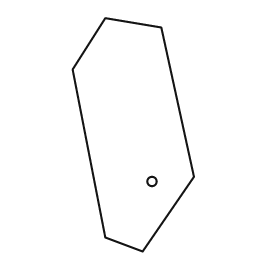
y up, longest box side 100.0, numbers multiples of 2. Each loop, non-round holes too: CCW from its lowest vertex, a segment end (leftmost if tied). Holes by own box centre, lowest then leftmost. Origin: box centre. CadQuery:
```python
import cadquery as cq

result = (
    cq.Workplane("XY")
    .moveTo(4.0, -50.0)
    .lineTo(26.0, -18.0)
    .lineTo(12.0, 46.0)
    .lineTo(-12.0, 50.0)
    .lineTo(-26.0, 28.0)
    .lineTo(-12.0, -44.0)
    .close()
    .moveTo(8.0, -20.0)
    .circle(2.0)
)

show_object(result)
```